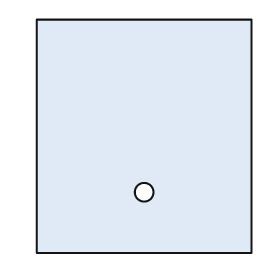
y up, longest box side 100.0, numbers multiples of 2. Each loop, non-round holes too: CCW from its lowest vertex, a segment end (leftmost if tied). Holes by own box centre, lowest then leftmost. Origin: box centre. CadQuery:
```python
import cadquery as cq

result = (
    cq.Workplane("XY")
    .moveTo(-46.0, -50.0)
    .lineTo(46.0, -50.0)
    .lineTo(46.0, 50.0)
    .lineTo(-46.0, 50.0)
    .close()
    .moveTo(0.0, -24.0)
    .circle(4.0)
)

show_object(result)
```